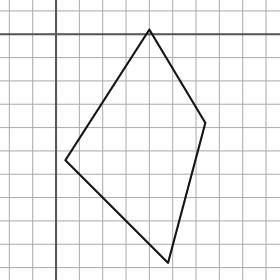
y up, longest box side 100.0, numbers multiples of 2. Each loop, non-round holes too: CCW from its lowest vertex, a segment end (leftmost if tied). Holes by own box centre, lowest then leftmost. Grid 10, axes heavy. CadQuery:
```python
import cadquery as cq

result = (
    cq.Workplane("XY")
    .moveTo(48.0, -98.0)
    .lineTo(64.0, -38.0)
    .lineTo(40.0, 2.0)
    .lineTo(4.0, -54.0)
    .close()
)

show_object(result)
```